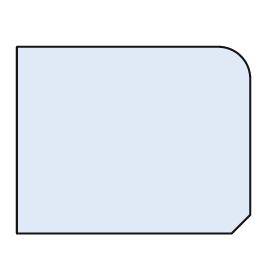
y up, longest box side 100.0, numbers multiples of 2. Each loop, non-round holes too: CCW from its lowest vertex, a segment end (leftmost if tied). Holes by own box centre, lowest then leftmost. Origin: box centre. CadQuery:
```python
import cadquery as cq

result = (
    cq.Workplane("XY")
    .moveTo(-50.0, -40.0)
    .lineTo(42.0, -40.0)
    .lineTo(50.0, -32.0)
    .lineTo(50.0, 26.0)
    .threePointArc((46.0, 36.0), (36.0, 40.0))
    .lineTo(-50.0, 40.0)
    .close()
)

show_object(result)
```